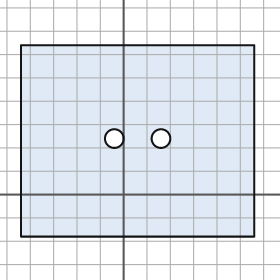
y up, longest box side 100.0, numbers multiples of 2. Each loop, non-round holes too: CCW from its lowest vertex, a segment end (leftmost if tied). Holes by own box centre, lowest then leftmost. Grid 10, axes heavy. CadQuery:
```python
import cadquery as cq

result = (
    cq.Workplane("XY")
    .moveTo(-44.0, -18.0)
    .lineTo(56.0, -18.0)
    .lineTo(56.0, 64.0)
    .lineTo(-44.0, 64.0)
    .close()
    .moveTo(-4.0, 24.0)
    .circle(4.0)
    .moveTo(16.0, 24.0)
    .circle(4.0)
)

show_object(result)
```